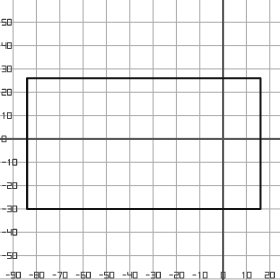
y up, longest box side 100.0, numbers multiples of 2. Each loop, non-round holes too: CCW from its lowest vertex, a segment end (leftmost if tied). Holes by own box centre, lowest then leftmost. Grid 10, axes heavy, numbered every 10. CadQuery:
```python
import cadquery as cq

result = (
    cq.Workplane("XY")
    .moveTo(-84.0, -30.0)
    .lineTo(16.0, -30.0)
    .lineTo(16.0, 26.0)
    .lineTo(-84.0, 26.0)
    .close()
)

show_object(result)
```